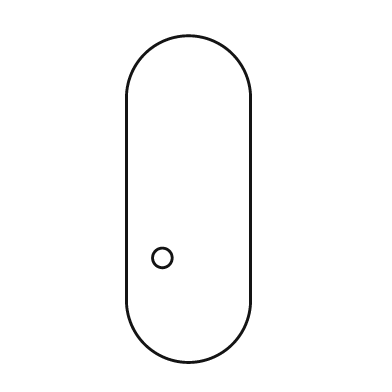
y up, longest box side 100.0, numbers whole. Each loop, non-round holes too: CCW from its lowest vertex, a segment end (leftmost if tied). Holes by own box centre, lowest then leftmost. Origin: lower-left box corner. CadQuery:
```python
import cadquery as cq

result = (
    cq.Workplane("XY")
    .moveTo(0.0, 19.0)
    .threePointArc((19.0, 0.0), (38.0, 19.0))
    .lineTo(38.0, 81.0)
    .threePointArc((19.0, 100.0), (0.0, 81.0))
    .close()
    .moveTo(11.0, 32.0)
    .circle(3.0)
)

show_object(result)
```